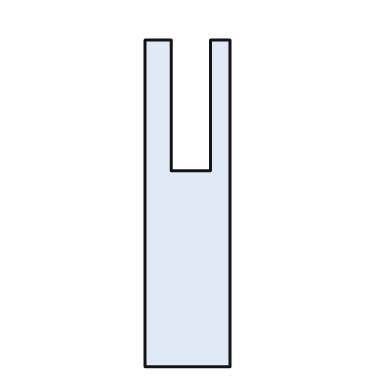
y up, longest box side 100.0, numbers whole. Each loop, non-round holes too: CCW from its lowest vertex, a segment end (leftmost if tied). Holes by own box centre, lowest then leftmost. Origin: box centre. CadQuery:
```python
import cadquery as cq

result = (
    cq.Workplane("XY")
    .moveTo(-13.0, -50.0)
    .lineTo(13.0, -50.0)
    .lineTo(13.0, 50.0)
    .lineTo(7.0, 50.0)
    .lineTo(7.0, 10.0)
    .lineTo(-5.0, 10.0)
    .lineTo(-5.0, 50.0)
    .lineTo(-13.0, 50.0)
    .close()
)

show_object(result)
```